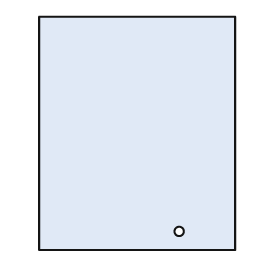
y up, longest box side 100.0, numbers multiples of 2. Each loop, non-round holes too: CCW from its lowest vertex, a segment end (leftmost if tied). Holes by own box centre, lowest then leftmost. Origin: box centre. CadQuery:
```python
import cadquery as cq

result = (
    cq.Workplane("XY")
    .moveTo(-42.0, -50.0)
    .lineTo(42.0, -50.0)
    .lineTo(42.0, 50.0)
    .lineTo(-42.0, 50.0)
    .close()
    .moveTo(18.0, -42.0)
    .circle(2.0)
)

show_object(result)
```